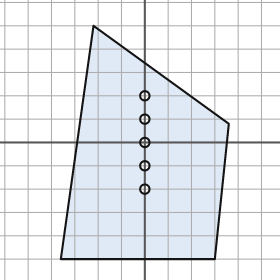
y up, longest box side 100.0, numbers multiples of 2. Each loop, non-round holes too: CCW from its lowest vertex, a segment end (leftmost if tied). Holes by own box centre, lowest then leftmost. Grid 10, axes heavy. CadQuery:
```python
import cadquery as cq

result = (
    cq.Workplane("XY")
    .moveTo(-36.0, -50.0)
    .lineTo(30.0, -50.0)
    .lineTo(36.0, 8.0)
    .lineTo(-22.0, 50.0)
    .close()
    .moveTo(0.0, -20.0)
    .circle(2.0)
    .moveTo(0.0, -10.0)
    .circle(2.0)
    .moveTo(0.0, 0.0)
    .circle(2.0)
    .moveTo(0.0, 10.0)
    .circle(2.0)
    .moveTo(0.0, 20.0)
    .circle(2.0)
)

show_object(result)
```